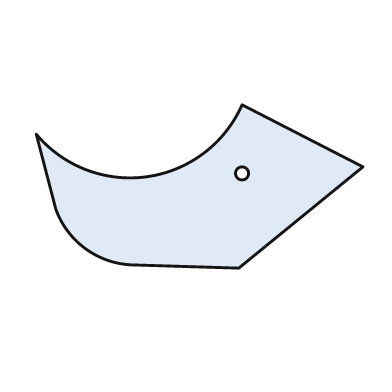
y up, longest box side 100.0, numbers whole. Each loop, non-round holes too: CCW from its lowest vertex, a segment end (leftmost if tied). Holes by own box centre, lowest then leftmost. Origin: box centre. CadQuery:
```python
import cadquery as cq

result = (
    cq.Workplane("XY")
    .moveTo(12.0, -25.0)
    .lineTo(50.0, 6.0)
    .lineTo(13.0, 25.0)
    .threePointArc((-16.0, 3.0), (-50.0, 16.0))
    .lineTo(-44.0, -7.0)
    .threePointArc((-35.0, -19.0), (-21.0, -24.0))
    .close()
    .moveTo(13.0, 4.0)
    .circle(2.0)
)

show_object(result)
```